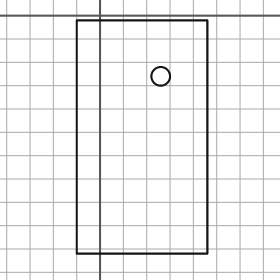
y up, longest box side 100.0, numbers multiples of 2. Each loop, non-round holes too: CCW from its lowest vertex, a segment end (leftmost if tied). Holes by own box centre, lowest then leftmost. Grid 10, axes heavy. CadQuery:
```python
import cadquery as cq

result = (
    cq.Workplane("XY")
    .moveTo(-10.0, -102.0)
    .lineTo(46.0, -102.0)
    .lineTo(46.0, -2.0)
    .lineTo(-10.0, -2.0)
    .close()
    .moveTo(26.0, -26.0)
    .circle(4.0)
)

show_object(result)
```